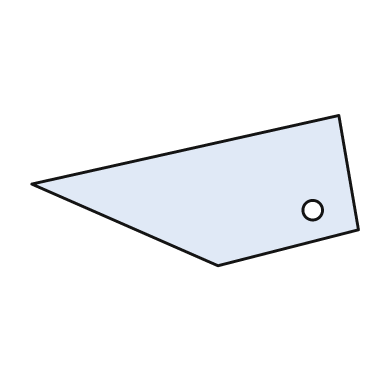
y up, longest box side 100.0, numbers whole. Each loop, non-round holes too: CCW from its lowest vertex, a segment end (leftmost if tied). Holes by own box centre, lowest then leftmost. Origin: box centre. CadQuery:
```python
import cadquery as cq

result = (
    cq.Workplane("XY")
    .moveTo(7.0, -23.0)
    .lineTo(50.0, -12.0)
    .lineTo(44.0, 23.0)
    .lineTo(-50.0, 2.0)
    .close()
    .moveTo(36.0, -6.0)
    .circle(3.0)
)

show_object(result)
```